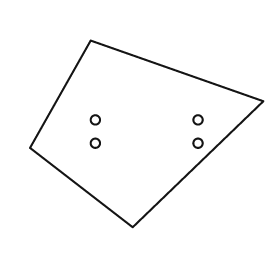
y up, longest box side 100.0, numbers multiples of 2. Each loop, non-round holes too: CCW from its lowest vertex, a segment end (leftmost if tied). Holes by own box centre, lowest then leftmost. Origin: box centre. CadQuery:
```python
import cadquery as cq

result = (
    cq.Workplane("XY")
    .moveTo(-6.0, -40.0)
    .lineTo(50.0, 14.0)
    .lineTo(-24.0, 40.0)
    .lineTo(-50.0, -6.0)
    .close()
    .moveTo(-22.0, -4.0)
    .circle(2.0)
    .moveTo(22.0, -4.0)
    .circle(2.0)
    .moveTo(-22.0, 6.0)
    .circle(2.0)
    .moveTo(22.0, 6.0)
    .circle(2.0)
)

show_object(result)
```